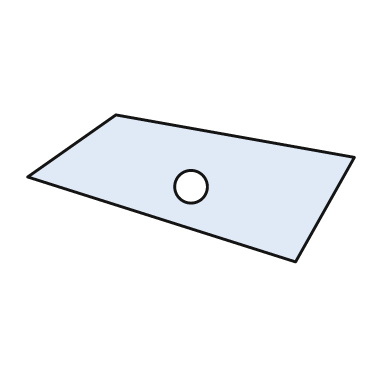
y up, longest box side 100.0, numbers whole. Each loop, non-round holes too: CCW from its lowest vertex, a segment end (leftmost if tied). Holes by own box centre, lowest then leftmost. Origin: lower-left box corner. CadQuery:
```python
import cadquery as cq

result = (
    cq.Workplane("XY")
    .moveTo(82.0, 0.0)
    .lineTo(100.0, 32.0)
    .lineTo(27.0, 45.0)
    .lineTo(0.0, 26.0)
    .close()
    .moveTo(50.0, 23.0)
    .circle(5.0)
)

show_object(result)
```